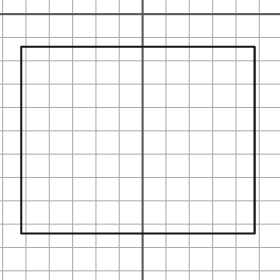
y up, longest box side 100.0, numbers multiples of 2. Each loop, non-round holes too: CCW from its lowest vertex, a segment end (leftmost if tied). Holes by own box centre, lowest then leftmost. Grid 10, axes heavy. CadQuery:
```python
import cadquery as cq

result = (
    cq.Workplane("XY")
    .moveTo(-52.0, -94.0)
    .lineTo(48.0, -94.0)
    .lineTo(48.0, -14.0)
    .lineTo(-52.0, -14.0)
    .close()
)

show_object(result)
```